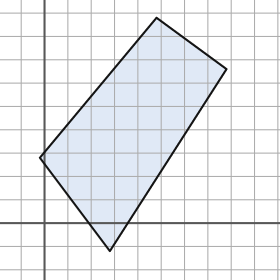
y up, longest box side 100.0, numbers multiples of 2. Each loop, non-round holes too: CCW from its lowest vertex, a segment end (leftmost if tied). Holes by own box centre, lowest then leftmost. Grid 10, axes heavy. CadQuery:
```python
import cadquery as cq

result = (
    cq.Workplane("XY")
    .moveTo(28.0, -12.0)
    .lineTo(78.0, 66.0)
    .lineTo(48.0, 88.0)
    .lineTo(-2.0, 28.0)
    .close()
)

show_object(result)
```